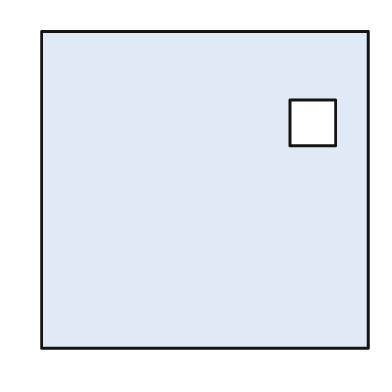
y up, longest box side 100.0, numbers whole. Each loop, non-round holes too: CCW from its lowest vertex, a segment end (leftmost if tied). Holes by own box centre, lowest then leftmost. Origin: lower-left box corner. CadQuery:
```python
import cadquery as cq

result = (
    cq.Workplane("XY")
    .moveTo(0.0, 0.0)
    .lineTo(100.0, 0.0)
    .lineTo(100.0, 97.0)
    .lineTo(0.0, 97.0)
    .close()
    .moveTo(76.0, 62.0)
    .lineTo(90.0, 62.0)
    .lineTo(90.0, 76.0)
    .lineTo(76.0, 76.0)
    .close()
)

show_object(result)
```